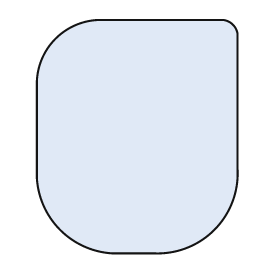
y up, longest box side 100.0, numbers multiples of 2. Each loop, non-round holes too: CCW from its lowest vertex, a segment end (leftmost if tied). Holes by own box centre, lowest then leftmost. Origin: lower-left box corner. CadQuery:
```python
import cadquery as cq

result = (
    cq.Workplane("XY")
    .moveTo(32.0, 0.0)
    .lineTo(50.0, 0.0)
    .threePointArc((76.0, 10.0), (86.0, 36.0))
    .lineTo(86.0, 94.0)
    .threePointArc((84.0, 98.0), (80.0, 100.0))
    .lineTo(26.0, 100.0)
    .threePointArc((8.0, 92.0), (0.0, 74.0))
    .lineTo(0.0, 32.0)
    .threePointArc((10.0, 10.0), (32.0, 0.0))
    .close()
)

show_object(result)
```